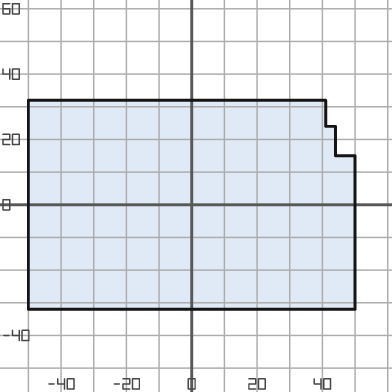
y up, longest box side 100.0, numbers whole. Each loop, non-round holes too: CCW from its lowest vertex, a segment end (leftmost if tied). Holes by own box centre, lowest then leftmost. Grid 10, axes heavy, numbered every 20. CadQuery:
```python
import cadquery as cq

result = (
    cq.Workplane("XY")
    .moveTo(-50.0, -32.0)
    .lineTo(50.0, -32.0)
    .lineTo(50.0, 15.0)
    .lineTo(44.0, 15.0)
    .lineTo(44.0, 24.0)
    .lineTo(41.0, 24.0)
    .lineTo(41.0, 32.0)
    .lineTo(-50.0, 32.0)
    .close()
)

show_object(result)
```